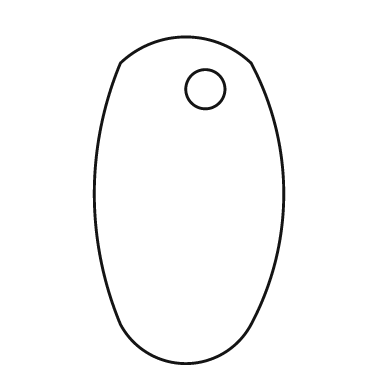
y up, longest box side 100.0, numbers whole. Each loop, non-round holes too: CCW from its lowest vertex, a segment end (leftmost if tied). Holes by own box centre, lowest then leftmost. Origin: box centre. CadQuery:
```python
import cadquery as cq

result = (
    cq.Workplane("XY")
    .moveTo(-21.0, -38.0)
    .threePointArc((-1.0, -50.0), (19.0, -38.0))
    .threePointArc((29.0, 2.0), (19.0, 42.0))
    .threePointArc((-1.0, 50.0), (-21.0, 42.0))
    .threePointArc((-29.0, 2.0), (-21.0, -38.0))
    .close()
    .moveTo(5.0, 34.0)
    .circle(6.0)
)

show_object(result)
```